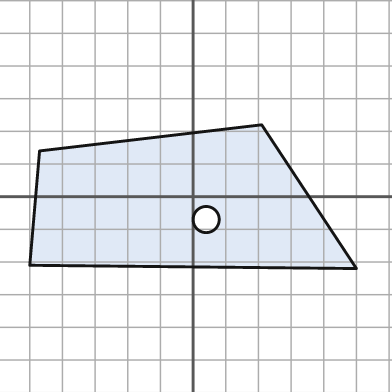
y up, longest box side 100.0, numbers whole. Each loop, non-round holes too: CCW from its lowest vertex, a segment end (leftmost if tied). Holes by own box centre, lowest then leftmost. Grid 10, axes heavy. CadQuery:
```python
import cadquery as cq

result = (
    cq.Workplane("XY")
    .moveTo(50.0, -22.0)
    .lineTo(21.0, 22.0)
    .lineTo(-47.0, 14.0)
    .lineTo(-50.0, -21.0)
    .close()
    .moveTo(4.0, -7.0)
    .circle(4.0)
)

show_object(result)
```